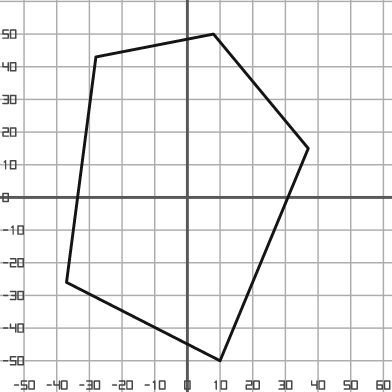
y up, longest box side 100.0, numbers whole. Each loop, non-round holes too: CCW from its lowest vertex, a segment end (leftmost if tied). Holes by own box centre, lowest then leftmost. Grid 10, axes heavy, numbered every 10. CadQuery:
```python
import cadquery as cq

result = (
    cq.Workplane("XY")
    .moveTo(10.0, -50.0)
    .lineTo(37.0, 15.0)
    .lineTo(8.0, 50.0)
    .lineTo(-28.0, 43.0)
    .lineTo(-37.0, -26.0)
    .close()
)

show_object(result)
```